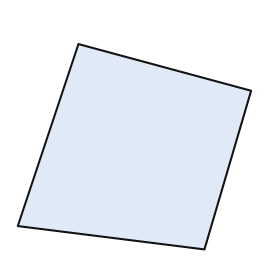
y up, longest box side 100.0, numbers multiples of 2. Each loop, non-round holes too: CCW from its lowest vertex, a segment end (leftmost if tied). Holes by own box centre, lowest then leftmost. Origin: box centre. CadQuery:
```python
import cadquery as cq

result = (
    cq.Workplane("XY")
    .moveTo(30.0, -44.0)
    .lineTo(50.0, 24.0)
    .lineTo(-24.0, 44.0)
    .lineTo(-50.0, -34.0)
    .close()
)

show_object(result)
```